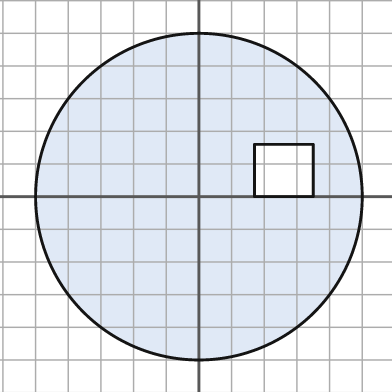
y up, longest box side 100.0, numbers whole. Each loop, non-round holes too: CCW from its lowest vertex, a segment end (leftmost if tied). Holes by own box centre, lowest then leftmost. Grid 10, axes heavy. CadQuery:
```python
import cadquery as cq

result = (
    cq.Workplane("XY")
    .moveTo(0.0, 0.0)
    .circle(50.0)
    .moveTo(17.0, 0.0)
    .lineTo(35.0, 0.0)
    .lineTo(35.0, 16.0)
    .lineTo(17.0, 16.0)
    .close()
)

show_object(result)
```